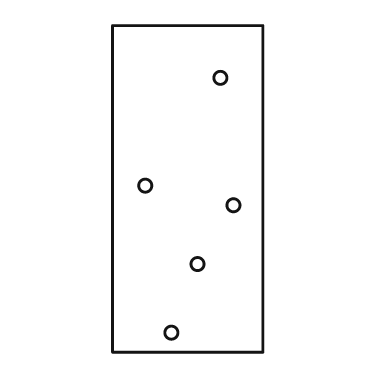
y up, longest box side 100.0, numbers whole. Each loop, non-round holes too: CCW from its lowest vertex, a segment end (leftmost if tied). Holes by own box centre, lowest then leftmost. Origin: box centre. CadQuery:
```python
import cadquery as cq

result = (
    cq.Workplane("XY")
    .moveTo(-23.0, -50.0)
    .lineTo(23.0, -50.0)
    .lineTo(23.0, 50.0)
    .lineTo(-23.0, 50.0)
    .close()
    .moveTo(-5.0, -44.0)
    .circle(2.0)
    .moveTo(3.0, -23.0)
    .circle(2.0)
    .moveTo(14.0, -5.0)
    .circle(2.0)
    .moveTo(-13.0, 1.0)
    .circle(2.0)
    .moveTo(10.0, 34.0)
    .circle(2.0)
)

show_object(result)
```